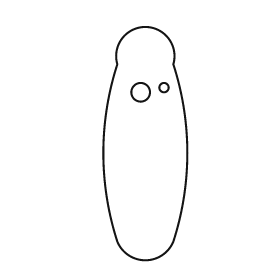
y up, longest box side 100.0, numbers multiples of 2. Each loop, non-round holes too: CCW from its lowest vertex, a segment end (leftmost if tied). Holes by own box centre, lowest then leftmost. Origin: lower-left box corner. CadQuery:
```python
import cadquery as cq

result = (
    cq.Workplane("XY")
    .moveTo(6.0, 8.0)
    .threePointArc((18.0, 0.0), (30.0, 8.0))
    .threePointArc((36.0, 46.0), (30.0, 84.0))
    .threePointArc((18.0, 100.0), (6.0, 84.0))
    .threePointArc((0.0, 46.0), (6.0, 8.0))
    .close()
    .moveTo(16.0, 72.0)
    .circle(4.0)
    .moveTo(26.0, 74.0)
    .circle(2.0)
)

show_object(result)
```